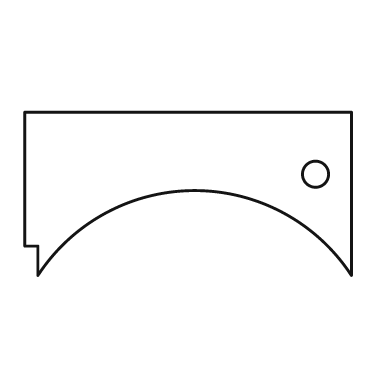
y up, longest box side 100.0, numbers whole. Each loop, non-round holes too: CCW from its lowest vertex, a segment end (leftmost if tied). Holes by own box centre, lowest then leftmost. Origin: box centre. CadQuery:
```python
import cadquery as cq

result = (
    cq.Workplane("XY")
    .moveTo(-46.0, -25.0)
    .threePointArc((2.0, 1.0), (50.0, -25.0))
    .lineTo(50.0, 25.0)
    .lineTo(-50.0, 25.0)
    .lineTo(-50.0, -16.0)
    .lineTo(-46.0, -16.0)
    .close()
    .moveTo(39.0, 6.0)
    .circle(4.0)
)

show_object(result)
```